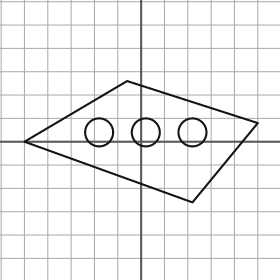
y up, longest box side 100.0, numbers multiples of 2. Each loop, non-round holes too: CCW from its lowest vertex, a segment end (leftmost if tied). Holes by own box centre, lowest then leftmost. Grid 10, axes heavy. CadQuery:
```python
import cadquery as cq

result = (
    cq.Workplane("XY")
    .moveTo(22.0, -26.0)
    .lineTo(50.0, 8.0)
    .lineTo(-6.0, 26.0)
    .lineTo(-50.0, 0.0)
    .close()
    .moveTo(-18.0, 4.0)
    .circle(6.0)
    .moveTo(2.0, 4.0)
    .circle(6.0)
    .moveTo(22.0, 4.0)
    .circle(6.0)
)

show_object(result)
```